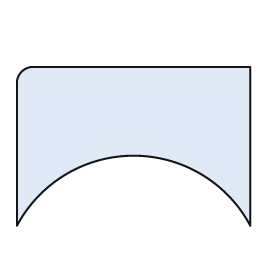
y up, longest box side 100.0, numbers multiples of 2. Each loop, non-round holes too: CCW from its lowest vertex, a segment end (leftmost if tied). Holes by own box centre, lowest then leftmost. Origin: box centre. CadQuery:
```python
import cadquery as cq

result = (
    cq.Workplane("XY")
    .moveTo(-50.0, -34.0)
    .threePointArc((0.0, -4.0), (50.0, -34.0))
    .lineTo(50.0, 34.0)
    .lineTo(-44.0, 34.0)
    .threePointArc((-48.0, 32.0), (-50.0, 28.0))
    .close()
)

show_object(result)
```